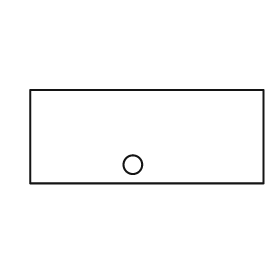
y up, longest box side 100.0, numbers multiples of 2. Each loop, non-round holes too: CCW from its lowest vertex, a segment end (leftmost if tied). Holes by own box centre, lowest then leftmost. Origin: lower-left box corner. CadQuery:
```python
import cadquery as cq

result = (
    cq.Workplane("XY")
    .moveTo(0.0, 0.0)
    .lineTo(100.0, 0.0)
    .lineTo(100.0, 40.0)
    .lineTo(0.0, 40.0)
    .close()
    .moveTo(44.0, 8.0)
    .circle(4.0)
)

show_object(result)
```